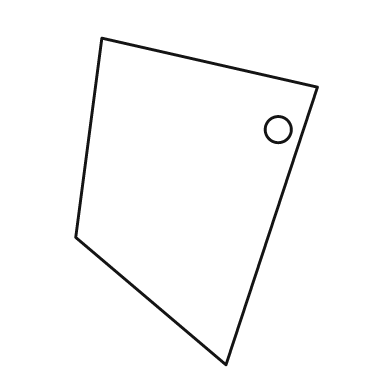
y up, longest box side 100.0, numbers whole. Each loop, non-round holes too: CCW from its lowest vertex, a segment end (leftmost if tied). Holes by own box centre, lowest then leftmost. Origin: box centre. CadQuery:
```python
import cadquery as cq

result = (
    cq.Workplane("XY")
    .moveTo(9.0, -50.0)
    .lineTo(37.0, 35.0)
    .lineTo(-29.0, 50.0)
    .lineTo(-37.0, -11.0)
    .close()
    .moveTo(25.0, 22.0)
    .circle(4.0)
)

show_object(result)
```